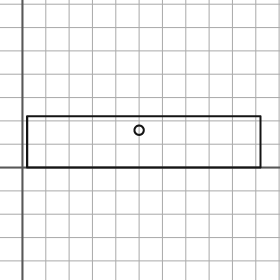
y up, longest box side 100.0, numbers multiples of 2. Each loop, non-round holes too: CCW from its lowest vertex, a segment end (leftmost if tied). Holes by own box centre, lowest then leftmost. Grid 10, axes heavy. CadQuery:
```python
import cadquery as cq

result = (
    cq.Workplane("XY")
    .moveTo(2.0, 0.0)
    .lineTo(102.0, 0.0)
    .lineTo(102.0, 22.0)
    .lineTo(2.0, 22.0)
    .close()
    .moveTo(50.0, 16.0)
    .circle(2.0)
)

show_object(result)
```